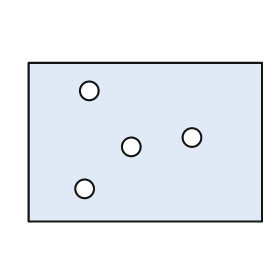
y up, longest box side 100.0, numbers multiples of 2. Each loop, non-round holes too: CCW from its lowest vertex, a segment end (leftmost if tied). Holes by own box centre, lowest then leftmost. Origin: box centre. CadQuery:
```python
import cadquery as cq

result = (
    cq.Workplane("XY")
    .moveTo(-50.0, -34.0)
    .lineTo(50.0, -34.0)
    .lineTo(50.0, 34.0)
    .lineTo(-50.0, 34.0)
    .close()
    .moveTo(-26.0, -20.0)
    .circle(4.0)
    .moveTo(-6.0, -2.0)
    .circle(4.0)
    .moveTo(20.0, 2.0)
    .circle(4.0)
    .moveTo(-24.0, 22.0)
    .circle(4.0)
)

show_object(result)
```